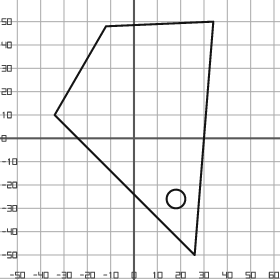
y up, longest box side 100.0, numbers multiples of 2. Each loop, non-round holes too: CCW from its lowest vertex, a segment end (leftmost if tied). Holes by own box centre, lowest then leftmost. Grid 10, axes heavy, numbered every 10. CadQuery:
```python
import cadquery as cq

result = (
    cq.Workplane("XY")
    .moveTo(26.0, -50.0)
    .lineTo(34.0, 50.0)
    .lineTo(-12.0, 48.0)
    .lineTo(-34.0, 10.0)
    .close()
    .moveTo(18.0, -26.0)
    .circle(4.0)
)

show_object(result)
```